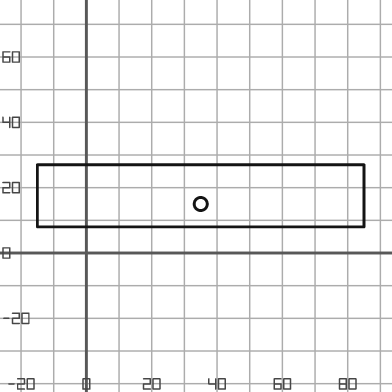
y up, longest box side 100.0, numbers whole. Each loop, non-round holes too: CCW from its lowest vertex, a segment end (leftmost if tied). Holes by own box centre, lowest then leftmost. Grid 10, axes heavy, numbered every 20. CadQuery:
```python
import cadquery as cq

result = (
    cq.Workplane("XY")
    .moveTo(-15.0, 8.0)
    .lineTo(85.0, 8.0)
    .lineTo(85.0, 27.0)
    .lineTo(-15.0, 27.0)
    .close()
    .moveTo(35.0, 15.0)
    .circle(2.0)
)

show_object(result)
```